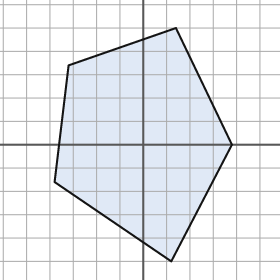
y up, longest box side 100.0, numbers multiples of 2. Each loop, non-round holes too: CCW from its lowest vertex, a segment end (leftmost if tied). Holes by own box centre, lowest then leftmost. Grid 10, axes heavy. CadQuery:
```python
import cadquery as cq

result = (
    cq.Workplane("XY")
    .moveTo(12.0, -50.0)
    .lineTo(38.0, 0.0)
    .lineTo(14.0, 50.0)
    .lineTo(-32.0, 34.0)
    .lineTo(-38.0, -16.0)
    .close()
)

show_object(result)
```